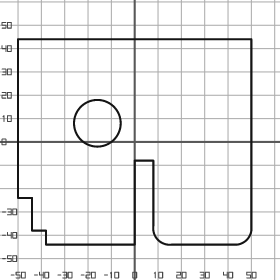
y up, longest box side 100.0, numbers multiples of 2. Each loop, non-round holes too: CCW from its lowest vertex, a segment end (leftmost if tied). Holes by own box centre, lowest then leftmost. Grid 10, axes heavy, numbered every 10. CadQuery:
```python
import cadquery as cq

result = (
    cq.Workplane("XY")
    .moveTo(-38.0, -44.0)
    .lineTo(0.0, -44.0)
    .lineTo(0.0, -8.0)
    .lineTo(8.0, -8.0)
    .lineTo(8.0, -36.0)
    .threePointArc((10.0, -42.0), (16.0, -44.0))
    .lineTo(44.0, -44.0)
    .threePointArc((48.0, -42.0), (50.0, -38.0))
    .lineTo(50.0, 44.0)
    .lineTo(-50.0, 44.0)
    .lineTo(-50.0, -24.0)
    .lineTo(-44.0, -24.0)
    .lineTo(-44.0, -38.0)
    .lineTo(-38.0, -38.0)
    .close()
    .moveTo(-16.0, 8.0)
    .circle(10.0)
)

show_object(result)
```